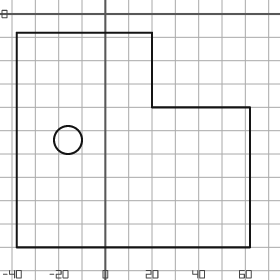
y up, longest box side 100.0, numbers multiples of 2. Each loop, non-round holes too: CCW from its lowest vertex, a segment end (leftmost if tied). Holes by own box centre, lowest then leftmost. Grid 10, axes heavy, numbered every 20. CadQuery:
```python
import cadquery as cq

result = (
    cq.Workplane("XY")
    .moveTo(-38.0, -100.0)
    .lineTo(62.0, -100.0)
    .lineTo(62.0, -40.0)
    .lineTo(20.0, -40.0)
    .lineTo(20.0, -8.0)
    .lineTo(-38.0, -8.0)
    .close()
    .moveTo(-16.0, -54.0)
    .circle(6.0)
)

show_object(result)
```